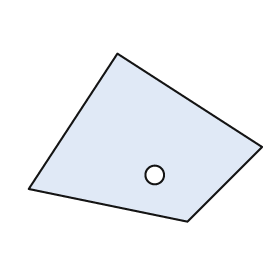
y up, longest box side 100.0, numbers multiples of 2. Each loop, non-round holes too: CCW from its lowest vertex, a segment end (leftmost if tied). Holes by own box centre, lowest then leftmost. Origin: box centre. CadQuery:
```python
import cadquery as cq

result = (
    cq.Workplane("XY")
    .moveTo(18.0, -36.0)
    .lineTo(50.0, -4.0)
    .lineTo(-12.0, 36.0)
    .lineTo(-50.0, -22.0)
    .close()
    .moveTo(4.0, -16.0)
    .circle(4.0)
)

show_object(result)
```